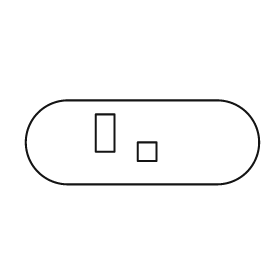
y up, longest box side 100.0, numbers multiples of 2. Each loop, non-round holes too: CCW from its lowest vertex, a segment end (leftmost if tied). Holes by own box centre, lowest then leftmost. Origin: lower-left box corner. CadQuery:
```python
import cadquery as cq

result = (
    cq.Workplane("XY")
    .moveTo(18.0, 0.0)
    .lineTo(82.0, 0.0)
    .threePointArc((100.0, 18.0), (82.0, 36.0))
    .lineTo(18.0, 36.0)
    .threePointArc((0.0, 18.0), (18.0, 0.0))
    .close()
    .moveTo(48.0, 10.0)
    .lineTo(56.0, 10.0)
    .lineTo(56.0, 18.0)
    .lineTo(48.0, 18.0)
    .close()
    .moveTo(30.0, 14.0)
    .lineTo(38.0, 14.0)
    .lineTo(38.0, 30.0)
    .lineTo(30.0, 30.0)
    .close()
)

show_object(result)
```